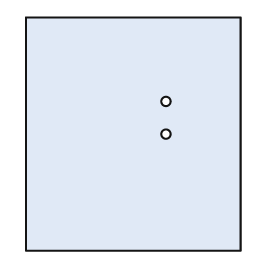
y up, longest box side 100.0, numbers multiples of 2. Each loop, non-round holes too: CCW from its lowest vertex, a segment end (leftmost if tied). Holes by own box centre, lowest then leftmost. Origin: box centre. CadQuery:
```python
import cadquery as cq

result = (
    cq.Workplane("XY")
    .moveTo(-46.0, -50.0)
    .lineTo(46.0, -50.0)
    .lineTo(46.0, 50.0)
    .lineTo(-46.0, 50.0)
    .close()
    .moveTo(14.0, 0.0)
    .circle(2.0)
    .moveTo(14.0, 14.0)
    .circle(2.0)
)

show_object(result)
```